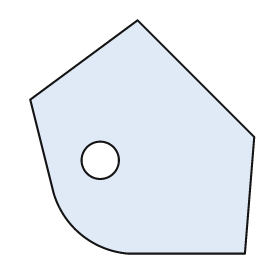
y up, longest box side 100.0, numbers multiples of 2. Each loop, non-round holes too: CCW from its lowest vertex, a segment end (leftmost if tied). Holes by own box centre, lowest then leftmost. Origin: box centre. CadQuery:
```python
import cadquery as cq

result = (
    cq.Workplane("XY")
    .moveTo(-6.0, -50.0)
    .lineTo(44.0, -50.0)
    .lineTo(48.0, 0.0)
    .lineTo(-2.0, 50.0)
    .lineTo(-48.0, 16.0)
    .lineTo(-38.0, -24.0)
    .threePointArc((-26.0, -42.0), (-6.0, -50.0))
    .close()
    .moveTo(-18.0, -10.0)
    .circle(8.0)
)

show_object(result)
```